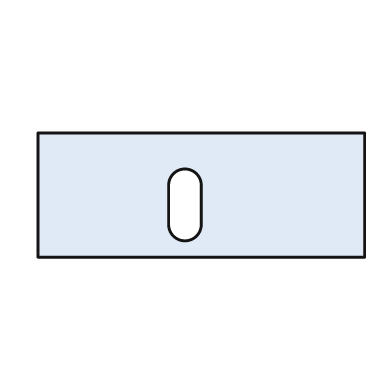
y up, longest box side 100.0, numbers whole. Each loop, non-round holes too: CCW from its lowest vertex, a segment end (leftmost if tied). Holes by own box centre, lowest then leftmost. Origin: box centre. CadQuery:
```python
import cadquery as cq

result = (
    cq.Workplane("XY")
    .moveTo(-50.0, -19.0)
    .lineTo(50.0, -19.0)
    .lineTo(50.0, 19.0)
    .lineTo(-50.0, 19.0)
    .close()
    .moveTo(-10.0, -9.0)
    .threePointArc((-5.0, -14.0), (0.0, -9.0))
    .lineTo(0.0, 3.0)
    .threePointArc((-5.0, 8.0), (-10.0, 3.0))
    .close()
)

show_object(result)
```